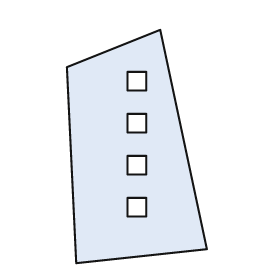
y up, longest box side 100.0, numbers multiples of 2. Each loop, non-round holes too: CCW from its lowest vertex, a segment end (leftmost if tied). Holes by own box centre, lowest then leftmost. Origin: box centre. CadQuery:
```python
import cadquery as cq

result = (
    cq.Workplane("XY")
    .moveTo(-26.0, -50.0)
    .lineTo(30.0, -44.0)
    .lineTo(10.0, 50.0)
    .lineTo(-30.0, 34.0)
    .close()
    .moveTo(-4.0, -30.0)
    .lineTo(4.0, -30.0)
    .lineTo(4.0, -22.0)
    .lineTo(-4.0, -22.0)
    .close()
    .moveTo(-4.0, -12.0)
    .lineTo(4.0, -12.0)
    .lineTo(4.0, -4.0)
    .lineTo(-4.0, -4.0)
    .close()
    .moveTo(-4.0, 6.0)
    .lineTo(4.0, 6.0)
    .lineTo(4.0, 14.0)
    .lineTo(-4.0, 14.0)
    .close()
    .moveTo(-4.0, 24.0)
    .lineTo(4.0, 24.0)
    .lineTo(4.0, 32.0)
    .lineTo(-4.0, 32.0)
    .close()
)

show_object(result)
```